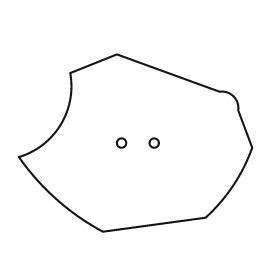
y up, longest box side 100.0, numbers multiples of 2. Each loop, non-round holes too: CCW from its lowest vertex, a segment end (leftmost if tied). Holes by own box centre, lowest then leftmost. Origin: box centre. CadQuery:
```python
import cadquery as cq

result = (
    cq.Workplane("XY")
    .moveTo(-14.0, -38.0)
    .lineTo(30.0, -32.0)
    .threePointArc((42.0, -18.0), (50.0, -2.0))
    .lineTo(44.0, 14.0)
    .threePointArc((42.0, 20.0), (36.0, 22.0))
    .lineTo(-8.0, 38.0)
    .lineTo(-28.0, 30.0)
    .threePointArc((-32.0, 8.0), (-50.0, -6.0))
    .threePointArc((-34.0, -24.0), (-14.0, -38.0))
    .close()
    .moveTo(-6.0, 0.0)
    .circle(2.0)
    .moveTo(8.0, 0.0)
    .circle(2.0)
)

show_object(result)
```